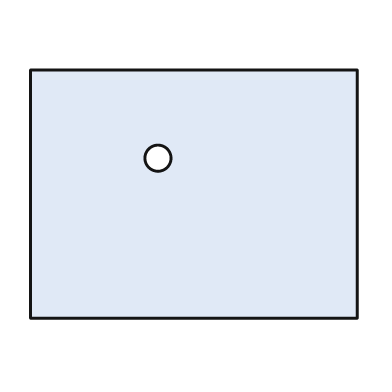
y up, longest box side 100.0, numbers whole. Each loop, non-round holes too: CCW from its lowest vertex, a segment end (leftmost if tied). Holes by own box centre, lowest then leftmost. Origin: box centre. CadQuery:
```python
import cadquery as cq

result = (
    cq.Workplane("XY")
    .moveTo(-50.0, -38.0)
    .lineTo(50.0, -38.0)
    .lineTo(50.0, 38.0)
    .lineTo(-50.0, 38.0)
    .close()
    .moveTo(-11.0, 11.0)
    .circle(4.0)
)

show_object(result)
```